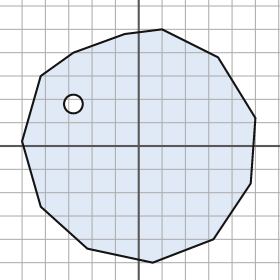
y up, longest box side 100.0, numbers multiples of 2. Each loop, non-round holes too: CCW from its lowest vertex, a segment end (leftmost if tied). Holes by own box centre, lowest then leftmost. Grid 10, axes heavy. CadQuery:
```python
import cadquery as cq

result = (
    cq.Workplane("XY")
    .moveTo(6.0, -50.0)
    .lineTo(32.0, -40.0)
    .lineTo(48.0, -16.0)
    .lineTo(50.0, 12.0)
    .lineTo(34.0, 38.0)
    .lineTo(10.0, 50.0)
    .lineTo(-6.0, 48.0)
    .lineTo(-28.0, 40.0)
    .lineTo(-42.0, 30.0)
    .lineTo(-50.0, 2.0)
    .lineTo(-42.0, -26.0)
    .lineTo(-22.0, -44.0)
    .close()
    .moveTo(-28.0, 18.0)
    .circle(4.0)
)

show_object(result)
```